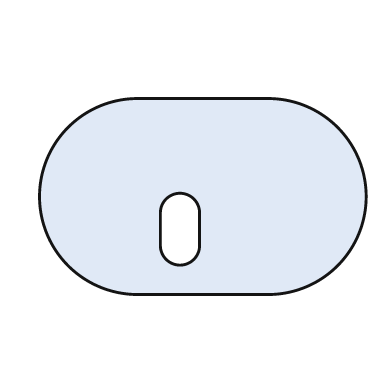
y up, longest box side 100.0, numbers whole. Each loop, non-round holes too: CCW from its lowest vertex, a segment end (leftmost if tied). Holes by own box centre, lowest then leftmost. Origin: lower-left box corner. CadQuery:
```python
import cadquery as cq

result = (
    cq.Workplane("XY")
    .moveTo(30.0, 0.0)
    .lineTo(70.0, 0.0)
    .threePointArc((100.0, 30.0), (70.0, 60.0))
    .lineTo(30.0, 60.0)
    .threePointArc((0.0, 30.0), (30.0, 0.0))
    .close()
    .moveTo(37.0, 15.0)
    .threePointArc((43.0, 9.0), (49.0, 15.0))
    .lineTo(49.0, 25.0)
    .threePointArc((43.0, 31.0), (37.0, 25.0))
    .close()
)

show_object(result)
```